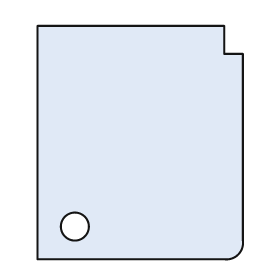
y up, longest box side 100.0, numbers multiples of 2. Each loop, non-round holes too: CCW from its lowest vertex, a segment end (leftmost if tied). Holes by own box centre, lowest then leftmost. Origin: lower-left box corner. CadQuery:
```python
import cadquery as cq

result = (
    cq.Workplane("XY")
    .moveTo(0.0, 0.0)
    .lineTo(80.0, 0.0)
    .threePointArc((86.0, 2.0), (88.0, 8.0))
    .lineTo(88.0, 88.0)
    .lineTo(80.0, 88.0)
    .lineTo(80.0, 100.0)
    .lineTo(0.0, 100.0)
    .close()
    .moveTo(16.0, 14.0)
    .circle(6.0)
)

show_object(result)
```